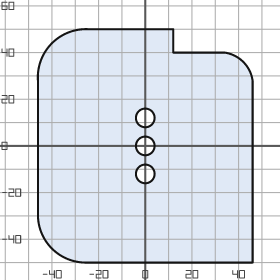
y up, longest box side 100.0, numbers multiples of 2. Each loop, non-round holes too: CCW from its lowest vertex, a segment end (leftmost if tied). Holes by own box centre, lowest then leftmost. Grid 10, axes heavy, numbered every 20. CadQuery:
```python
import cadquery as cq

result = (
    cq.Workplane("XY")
    .moveTo(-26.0, -50.0)
    .lineTo(46.0, -50.0)
    .lineTo(46.0, 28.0)
    .threePointArc((42.0, 36.0), (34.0, 40.0))
    .lineTo(12.0, 40.0)
    .lineTo(12.0, 50.0)
    .lineTo(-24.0, 50.0)
    .threePointArc((-40.0, 44.0), (-46.0, 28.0))
    .lineTo(-46.0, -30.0)
    .threePointArc((-40.0, -44.0), (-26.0, -50.0))
    .close()
    .moveTo(0.0, -12.0)
    .circle(4.0)
    .moveTo(0.0, 0.0)
    .circle(4.0)
    .moveTo(0.0, 12.0)
    .circle(4.0)
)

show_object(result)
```